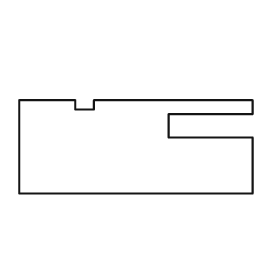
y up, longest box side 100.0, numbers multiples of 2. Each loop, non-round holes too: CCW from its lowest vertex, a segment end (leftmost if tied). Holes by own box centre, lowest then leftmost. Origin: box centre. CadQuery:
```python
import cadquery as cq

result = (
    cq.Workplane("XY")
    .moveTo(-50.0, -20.0)
    .lineTo(50.0, -20.0)
    .lineTo(50.0, 4.0)
    .lineTo(14.0, 4.0)
    .lineTo(14.0, 14.0)
    .lineTo(50.0, 14.0)
    .lineTo(50.0, 20.0)
    .lineTo(-18.0, 20.0)
    .lineTo(-18.0, 16.0)
    .lineTo(-26.0, 16.0)
    .lineTo(-26.0, 20.0)
    .lineTo(-50.0, 20.0)
    .close()
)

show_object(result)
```